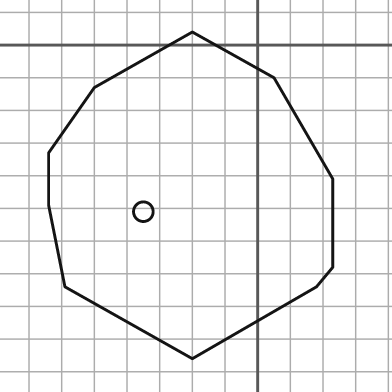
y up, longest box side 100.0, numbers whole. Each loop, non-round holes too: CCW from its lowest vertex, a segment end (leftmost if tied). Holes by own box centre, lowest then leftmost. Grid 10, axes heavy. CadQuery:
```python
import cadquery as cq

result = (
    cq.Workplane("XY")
    .moveTo(-20.0, -96.0)
    .lineTo(18.0, -74.0)
    .lineTo(23.0, -68.0)
    .lineTo(23.0, -41.0)
    .lineTo(5.0, -10.0)
    .lineTo(-20.0, 4.0)
    .lineTo(-50.0, -13.0)
    .lineTo(-64.0, -33.0)
    .lineTo(-64.0, -49.0)
    .lineTo(-59.0, -74.0)
    .close()
    .moveTo(-35.0, -51.0)
    .circle(3.0)
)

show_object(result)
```